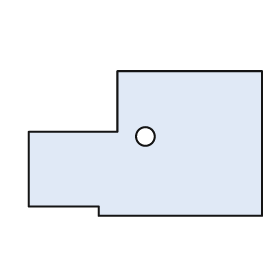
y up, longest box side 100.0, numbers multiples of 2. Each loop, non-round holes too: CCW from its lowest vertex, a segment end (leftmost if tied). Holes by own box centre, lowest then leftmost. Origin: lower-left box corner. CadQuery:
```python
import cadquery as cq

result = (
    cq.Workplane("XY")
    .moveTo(30.0, 0.0)
    .lineTo(100.0, 0.0)
    .lineTo(100.0, 62.0)
    .lineTo(38.0, 62.0)
    .lineTo(38.0, 36.0)
    .lineTo(0.0, 36.0)
    .lineTo(0.0, 4.0)
    .lineTo(30.0, 4.0)
    .close()
    .moveTo(50.0, 34.0)
    .circle(4.0)
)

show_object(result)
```